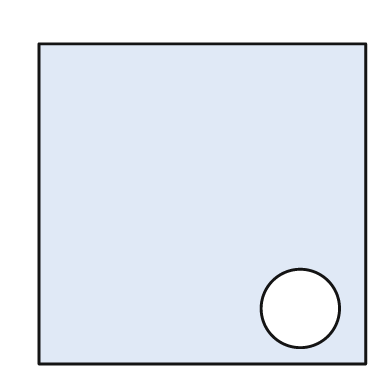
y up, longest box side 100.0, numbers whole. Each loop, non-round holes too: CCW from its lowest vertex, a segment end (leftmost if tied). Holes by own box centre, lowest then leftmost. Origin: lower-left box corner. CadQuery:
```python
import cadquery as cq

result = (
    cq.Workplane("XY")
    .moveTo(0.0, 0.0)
    .lineTo(100.0, 0.0)
    .lineTo(100.0, 98.0)
    .lineTo(0.0, 98.0)
    .close()
    .moveTo(80.0, 17.0)
    .circle(12.0)
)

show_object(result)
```